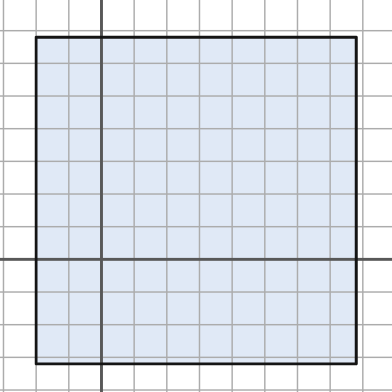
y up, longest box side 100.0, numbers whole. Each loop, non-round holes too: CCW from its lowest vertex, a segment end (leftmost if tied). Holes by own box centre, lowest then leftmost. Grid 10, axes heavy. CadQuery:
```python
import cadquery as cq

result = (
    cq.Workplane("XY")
    .moveTo(-20.0, -32.0)
    .lineTo(78.0, -32.0)
    .lineTo(78.0, 68.0)
    .lineTo(-20.0, 68.0)
    .close()
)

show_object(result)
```